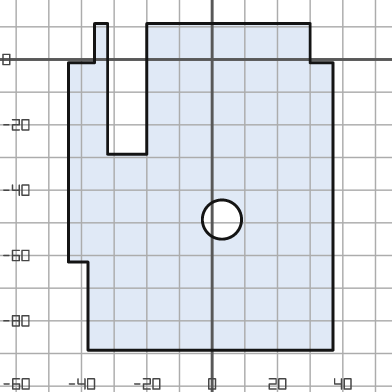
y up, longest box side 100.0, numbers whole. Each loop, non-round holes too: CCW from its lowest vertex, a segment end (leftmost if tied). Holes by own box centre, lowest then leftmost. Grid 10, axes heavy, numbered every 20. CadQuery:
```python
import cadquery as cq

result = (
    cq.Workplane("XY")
    .moveTo(-38.0, -89.0)
    .lineTo(37.0, -89.0)
    .lineTo(37.0, -1.0)
    .lineTo(30.0, -1.0)
    .lineTo(30.0, 11.0)
    .lineTo(-20.0, 11.0)
    .lineTo(-20.0, -29.0)
    .lineTo(-32.0, -29.0)
    .lineTo(-32.0, 11.0)
    .lineTo(-36.0, 11.0)
    .lineTo(-36.0, -1.0)
    .lineTo(-44.0, -1.0)
    .lineTo(-44.0, -62.0)
    .lineTo(-38.0, -62.0)
    .close()
    .moveTo(3.0, -49.0)
    .circle(6.0)
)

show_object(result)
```